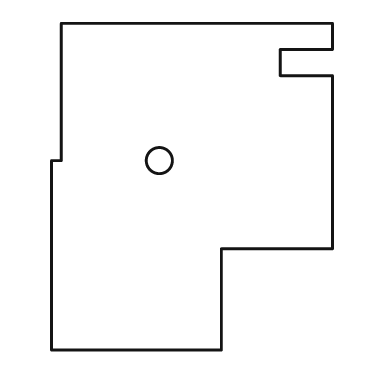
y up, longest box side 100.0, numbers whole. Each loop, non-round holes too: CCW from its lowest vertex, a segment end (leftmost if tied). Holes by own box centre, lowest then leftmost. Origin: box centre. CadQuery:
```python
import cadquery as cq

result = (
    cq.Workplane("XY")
    .moveTo(-43.0, -50.0)
    .lineTo(9.0, -50.0)
    .lineTo(9.0, -19.0)
    .lineTo(43.0, -19.0)
    .lineTo(43.0, 34.0)
    .lineTo(27.0, 34.0)
    .lineTo(27.0, 42.0)
    .lineTo(43.0, 42.0)
    .lineTo(43.0, 50.0)
    .lineTo(-40.0, 50.0)
    .lineTo(-40.0, 8.0)
    .lineTo(-43.0, 8.0)
    .close()
    .moveTo(-10.0, 8.0)
    .circle(4.0)
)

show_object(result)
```